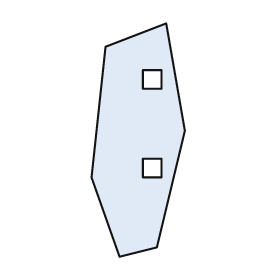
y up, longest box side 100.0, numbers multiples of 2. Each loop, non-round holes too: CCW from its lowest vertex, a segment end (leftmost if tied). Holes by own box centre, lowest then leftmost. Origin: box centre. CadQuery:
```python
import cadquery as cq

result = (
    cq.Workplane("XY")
    .moveTo(-8.0, -50.0)
    .lineTo(8.0, -46.0)
    .lineTo(20.0, 4.0)
    .lineTo(12.0, 50.0)
    .lineTo(-14.0, 40.0)
    .lineTo(-20.0, -16.0)
    .close()
    .moveTo(2.0, -16.0)
    .lineTo(10.0, -16.0)
    .lineTo(10.0, -8.0)
    .lineTo(2.0, -8.0)
    .close()
    .moveTo(2.0, 22.0)
    .lineTo(10.0, 22.0)
    .lineTo(10.0, 30.0)
    .lineTo(2.0, 30.0)
    .close()
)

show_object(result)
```